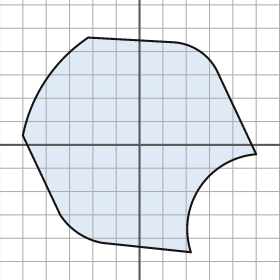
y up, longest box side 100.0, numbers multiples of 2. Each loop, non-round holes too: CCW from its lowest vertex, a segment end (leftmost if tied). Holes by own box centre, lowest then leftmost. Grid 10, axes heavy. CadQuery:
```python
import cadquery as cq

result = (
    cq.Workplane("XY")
    .moveTo(22.0, -46.0)
    .threePointArc((26.0, -18.0), (50.0, -4.0))
    .lineTo(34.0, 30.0)
    .threePointArc((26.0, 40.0), (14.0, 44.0))
    .lineTo(-22.0, 46.0)
    .threePointArc((-40.0, 28.0), (-50.0, 4.0))
    .lineTo(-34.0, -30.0)
    .threePointArc((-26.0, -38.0), (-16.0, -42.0))
    .close()
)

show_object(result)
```